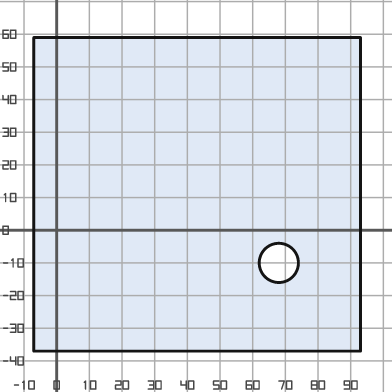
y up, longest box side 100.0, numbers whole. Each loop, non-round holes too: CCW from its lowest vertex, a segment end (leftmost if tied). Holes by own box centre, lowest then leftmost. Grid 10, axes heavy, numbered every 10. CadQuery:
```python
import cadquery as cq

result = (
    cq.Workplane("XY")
    .moveTo(-7.0, -37.0)
    .lineTo(93.0, -37.0)
    .lineTo(93.0, 59.0)
    .lineTo(-7.0, 59.0)
    .close()
    .moveTo(68.0, -10.0)
    .circle(6.0)
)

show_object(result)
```